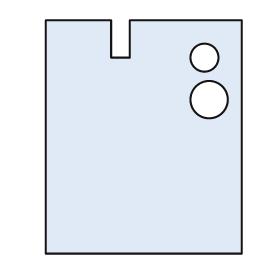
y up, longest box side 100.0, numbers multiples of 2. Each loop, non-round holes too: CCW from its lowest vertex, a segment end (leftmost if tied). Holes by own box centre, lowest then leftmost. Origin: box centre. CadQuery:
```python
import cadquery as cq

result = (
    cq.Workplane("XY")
    .moveTo(-42.0, -50.0)
    .lineTo(42.0, -50.0)
    .lineTo(42.0, 50.0)
    .lineTo(-6.0, 50.0)
    .lineTo(-6.0, 34.0)
    .lineTo(-14.0, 34.0)
    .lineTo(-14.0, 50.0)
    .lineTo(-42.0, 50.0)
    .close()
    .moveTo(28.0, 16.0)
    .circle(8.0)
    .moveTo(26.0, 34.0)
    .circle(6.0)
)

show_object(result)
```